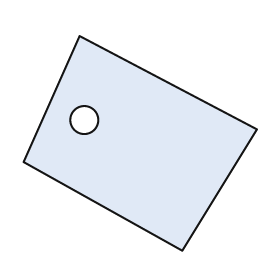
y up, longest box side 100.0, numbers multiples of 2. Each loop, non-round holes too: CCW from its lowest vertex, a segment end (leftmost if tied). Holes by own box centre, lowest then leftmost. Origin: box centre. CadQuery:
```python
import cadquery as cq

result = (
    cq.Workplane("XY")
    .moveTo(18.0, -46.0)
    .lineTo(50.0, 6.0)
    .lineTo(-26.0, 46.0)
    .lineTo(-50.0, -8.0)
    .close()
    .moveTo(-24.0, 10.0)
    .circle(6.0)
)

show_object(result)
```